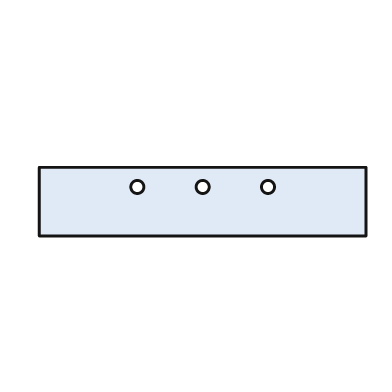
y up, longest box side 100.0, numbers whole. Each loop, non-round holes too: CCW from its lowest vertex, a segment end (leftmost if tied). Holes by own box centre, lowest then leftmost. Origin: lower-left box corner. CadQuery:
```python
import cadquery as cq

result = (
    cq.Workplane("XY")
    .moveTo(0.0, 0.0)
    .lineTo(100.0, 0.0)
    .lineTo(100.0, 21.0)
    .lineTo(0.0, 21.0)
    .close()
    .moveTo(30.0, 15.0)
    .circle(2.0)
    .moveTo(50.0, 15.0)
    .circle(2.0)
    .moveTo(70.0, 15.0)
    .circle(2.0)
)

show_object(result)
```